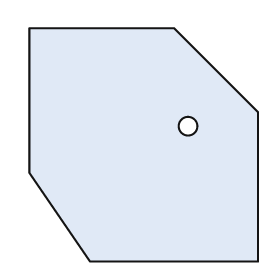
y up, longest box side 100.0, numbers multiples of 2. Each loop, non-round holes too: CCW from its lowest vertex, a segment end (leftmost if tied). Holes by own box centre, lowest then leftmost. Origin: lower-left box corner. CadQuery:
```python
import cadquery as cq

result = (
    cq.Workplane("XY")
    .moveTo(26.0, 0.0)
    .lineTo(98.0, 0.0)
    .lineTo(98.0, 64.0)
    .lineTo(62.0, 100.0)
    .lineTo(0.0, 100.0)
    .lineTo(0.0, 38.0)
    .close()
    .moveTo(68.0, 58.0)
    .circle(4.0)
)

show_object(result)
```